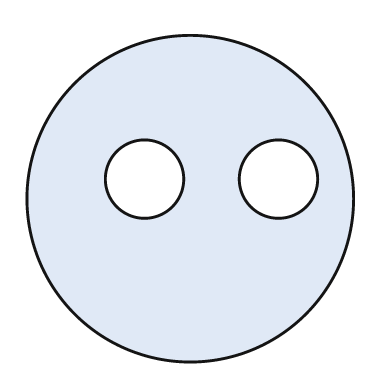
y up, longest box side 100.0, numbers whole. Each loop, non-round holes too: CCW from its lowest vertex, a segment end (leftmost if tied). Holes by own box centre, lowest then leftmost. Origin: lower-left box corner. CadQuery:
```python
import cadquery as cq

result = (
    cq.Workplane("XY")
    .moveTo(50.0, 50.0)
    .circle(50.0)
    .moveTo(36.0, 56.0)
    .circle(12.0)
    .moveTo(77.0, 56.0)
    .circle(12.0)
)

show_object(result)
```